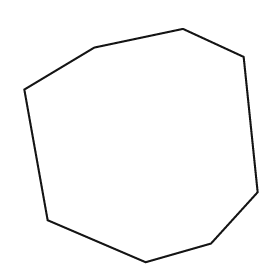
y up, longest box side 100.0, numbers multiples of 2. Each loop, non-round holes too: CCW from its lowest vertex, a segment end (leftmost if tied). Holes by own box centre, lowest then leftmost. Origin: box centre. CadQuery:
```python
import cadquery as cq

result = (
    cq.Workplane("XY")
    .moveTo(2.0, -50.0)
    .lineTo(30.0, -42.0)
    .lineTo(50.0, -20.0)
    .lineTo(44.0, 38.0)
    .lineTo(18.0, 50.0)
    .lineTo(-20.0, 42.0)
    .lineTo(-50.0, 24.0)
    .lineTo(-40.0, -32.0)
    .close()
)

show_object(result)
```